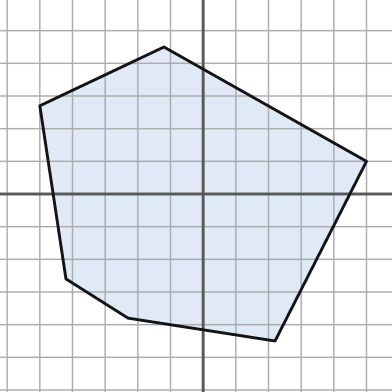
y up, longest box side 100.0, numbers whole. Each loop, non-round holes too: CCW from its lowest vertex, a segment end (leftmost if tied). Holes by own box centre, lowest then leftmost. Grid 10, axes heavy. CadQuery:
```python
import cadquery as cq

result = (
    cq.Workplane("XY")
    .moveTo(22.0, -45.0)
    .lineTo(50.0, 10.0)
    .lineTo(-12.0, 45.0)
    .lineTo(-50.0, 27.0)
    .lineTo(-42.0, -26.0)
    .lineTo(-23.0, -38.0)
    .close()
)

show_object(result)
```